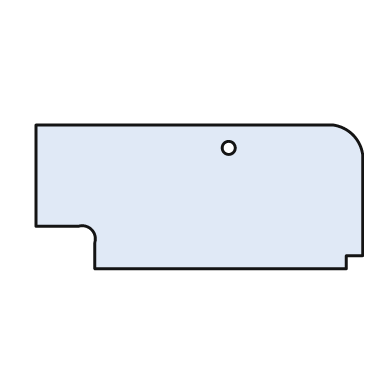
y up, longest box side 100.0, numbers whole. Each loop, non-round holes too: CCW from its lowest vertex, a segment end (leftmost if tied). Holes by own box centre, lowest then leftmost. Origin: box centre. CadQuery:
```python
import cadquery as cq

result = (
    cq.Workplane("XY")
    .moveTo(-32.0, -22.0)
    .lineTo(45.0, -22.0)
    .lineTo(45.0, -18.0)
    .lineTo(50.0, -18.0)
    .lineTo(50.0, 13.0)
    .threePointArc((47.0, 19.0), (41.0, 22.0))
    .lineTo(-50.0, 22.0)
    .lineTo(-50.0, -9.0)
    .lineTo(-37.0, -9.0)
    .threePointArc((-33.0, -10.0), (-32.0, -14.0))
    .close()
    .moveTo(9.0, 15.0)
    .circle(2.0)
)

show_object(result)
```